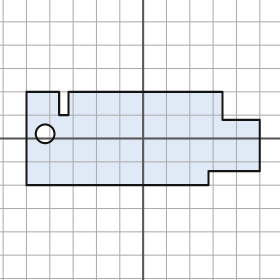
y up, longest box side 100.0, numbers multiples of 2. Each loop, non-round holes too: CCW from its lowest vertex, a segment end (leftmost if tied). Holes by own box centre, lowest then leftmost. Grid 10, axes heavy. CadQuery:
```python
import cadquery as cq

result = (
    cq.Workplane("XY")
    .moveTo(-50.0, -20.0)
    .lineTo(28.0, -20.0)
    .lineTo(28.0, -14.0)
    .lineTo(50.0, -14.0)
    .lineTo(50.0, 8.0)
    .lineTo(34.0, 8.0)
    .lineTo(34.0, 20.0)
    .lineTo(-32.0, 20.0)
    .lineTo(-32.0, 10.0)
    .lineTo(-36.0, 10.0)
    .lineTo(-36.0, 20.0)
    .lineTo(-50.0, 20.0)
    .close()
    .moveTo(-42.0, 2.0)
    .circle(4.0)
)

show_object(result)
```